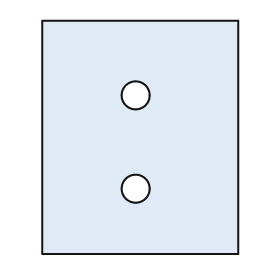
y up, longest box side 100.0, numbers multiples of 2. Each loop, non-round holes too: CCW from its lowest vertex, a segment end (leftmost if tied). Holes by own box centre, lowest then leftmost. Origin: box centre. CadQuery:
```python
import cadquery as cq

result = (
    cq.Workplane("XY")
    .moveTo(-42.0, -50.0)
    .lineTo(42.0, -50.0)
    .lineTo(42.0, 50.0)
    .lineTo(-42.0, 50.0)
    .close()
    .moveTo(-2.0, -22.0)
    .circle(6.0)
    .moveTo(-2.0, 18.0)
    .circle(6.0)
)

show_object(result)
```